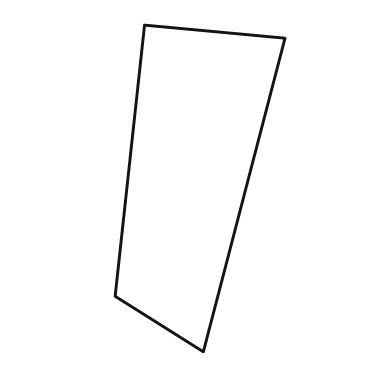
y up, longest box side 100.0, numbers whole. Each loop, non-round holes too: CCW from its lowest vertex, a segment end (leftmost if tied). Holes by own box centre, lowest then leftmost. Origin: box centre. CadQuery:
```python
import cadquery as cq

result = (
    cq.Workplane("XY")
    .moveTo(1.0, -50.0)
    .lineTo(26.0, 46.0)
    .lineTo(-17.0, 50.0)
    .lineTo(-26.0, -33.0)
    .close()
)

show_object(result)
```